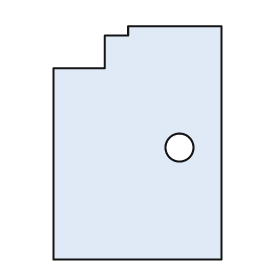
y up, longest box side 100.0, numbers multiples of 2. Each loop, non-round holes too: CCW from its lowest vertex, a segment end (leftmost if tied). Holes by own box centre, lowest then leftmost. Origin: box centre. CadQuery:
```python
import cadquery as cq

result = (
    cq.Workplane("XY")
    .moveTo(-36.0, -50.0)
    .lineTo(36.0, -50.0)
    .lineTo(36.0, 50.0)
    .lineTo(-4.0, 50.0)
    .lineTo(-4.0, 46.0)
    .lineTo(-14.0, 46.0)
    .lineTo(-14.0, 32.0)
    .lineTo(-36.0, 32.0)
    .close()
    .moveTo(18.0, -2.0)
    .circle(6.0)
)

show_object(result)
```